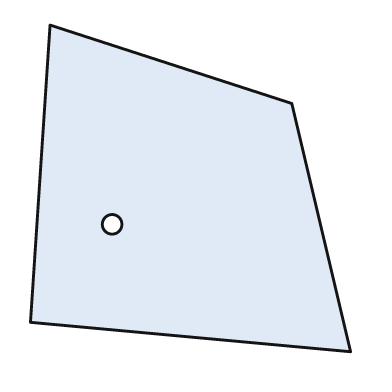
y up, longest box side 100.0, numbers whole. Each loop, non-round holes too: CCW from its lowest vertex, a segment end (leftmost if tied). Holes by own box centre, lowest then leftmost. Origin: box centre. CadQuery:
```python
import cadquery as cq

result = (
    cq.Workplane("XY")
    .moveTo(49.0, -50.0)
    .lineTo(31.0, 26.0)
    .lineTo(-43.0, 50.0)
    .lineTo(-49.0, -41.0)
    .close()
    .moveTo(-24.0, -11.0)
    .circle(3.0)
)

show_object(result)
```